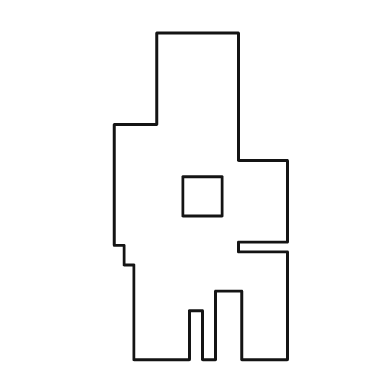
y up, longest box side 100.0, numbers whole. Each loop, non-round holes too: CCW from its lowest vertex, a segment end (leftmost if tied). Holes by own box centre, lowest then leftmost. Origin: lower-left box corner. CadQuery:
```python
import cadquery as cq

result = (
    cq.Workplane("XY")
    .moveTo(6.0, 0.0)
    .lineTo(23.0, 0.0)
    .lineTo(23.0, 15.0)
    .lineTo(27.0, 15.0)
    .lineTo(27.0, 0.0)
    .lineTo(31.0, 0.0)
    .lineTo(31.0, 21.0)
    .lineTo(39.0, 21.0)
    .lineTo(39.0, 0.0)
    .lineTo(53.0, 0.0)
    .lineTo(53.0, 33.0)
    .lineTo(38.0, 33.0)
    .lineTo(38.0, 36.0)
    .lineTo(53.0, 36.0)
    .lineTo(53.0, 61.0)
    .lineTo(38.0, 61.0)
    .lineTo(38.0, 100.0)
    .lineTo(13.0, 100.0)
    .lineTo(13.0, 72.0)
    .lineTo(0.0, 72.0)
    .lineTo(0.0, 35.0)
    .lineTo(3.0, 35.0)
    .lineTo(3.0, 29.0)
    .lineTo(6.0, 29.0)
    .close()
    .moveTo(21.0, 44.0)
    .lineTo(33.0, 44.0)
    .lineTo(33.0, 56.0)
    .lineTo(21.0, 56.0)
    .close()
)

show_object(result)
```